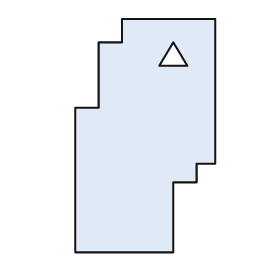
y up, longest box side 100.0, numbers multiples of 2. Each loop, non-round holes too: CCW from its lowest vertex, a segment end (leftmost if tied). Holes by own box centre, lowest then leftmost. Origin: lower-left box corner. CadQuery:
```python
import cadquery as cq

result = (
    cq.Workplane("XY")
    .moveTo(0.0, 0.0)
    .lineTo(42.0, 0.0)
    .lineTo(42.0, 30.0)
    .lineTo(52.0, 30.0)
    .lineTo(52.0, 38.0)
    .lineTo(60.0, 38.0)
    .lineTo(60.0, 100.0)
    .lineTo(20.0, 100.0)
    .lineTo(20.0, 90.0)
    .lineTo(10.0, 90.0)
    .lineTo(10.0, 62.0)
    .lineTo(0.0, 62.0)
    .close()
    .moveTo(36.0, 80.0)
    .lineTo(48.0, 80.0)
    .lineTo(42.0, 90.0)
    .close()
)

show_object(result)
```